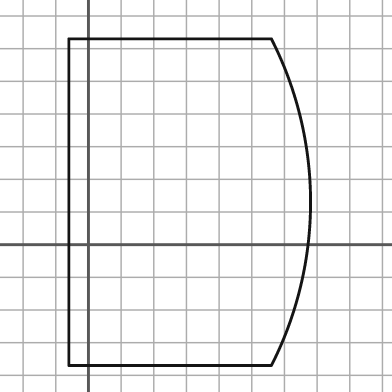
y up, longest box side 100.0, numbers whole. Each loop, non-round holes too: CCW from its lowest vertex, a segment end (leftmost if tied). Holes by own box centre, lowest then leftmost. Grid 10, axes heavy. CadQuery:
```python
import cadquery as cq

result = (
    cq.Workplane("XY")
    .moveTo(-6.0, -37.0)
    .lineTo(56.0, -37.0)
    .threePointArc((68.0, 13.0), (56.0, 63.0))
    .lineTo(-6.0, 63.0)
    .close()
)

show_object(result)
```